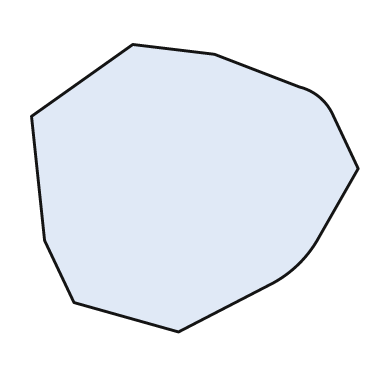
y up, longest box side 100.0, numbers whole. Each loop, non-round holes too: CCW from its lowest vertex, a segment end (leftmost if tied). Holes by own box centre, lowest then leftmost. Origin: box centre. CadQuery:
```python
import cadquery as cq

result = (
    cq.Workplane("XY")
    .moveTo(-5.0, -44.0)
    .lineTo(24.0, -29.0)
    .threePointArc((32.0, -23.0), (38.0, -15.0))
    .lineTo(50.0, 6.0)
    .lineTo(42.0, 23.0)
    .threePointArc((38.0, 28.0), (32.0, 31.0))
    .lineTo(6.0, 41.0)
    .lineTo(-19.0, 44.0)
    .lineTo(-50.0, 22.0)
    .lineTo(-46.0, -16.0)
    .lineTo(-37.0, -35.0)
    .close()
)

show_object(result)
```